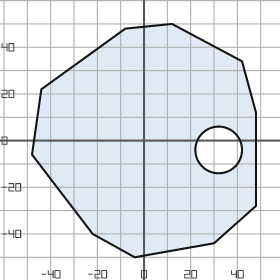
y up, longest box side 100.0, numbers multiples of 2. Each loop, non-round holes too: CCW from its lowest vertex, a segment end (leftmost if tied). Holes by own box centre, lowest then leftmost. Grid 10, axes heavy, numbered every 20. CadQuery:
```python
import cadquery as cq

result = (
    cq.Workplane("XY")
    .moveTo(-4.0, -50.0)
    .lineTo(30.0, -44.0)
    .lineTo(48.0, -28.0)
    .lineTo(48.0, 12.0)
    .lineTo(42.0, 34.0)
    .lineTo(12.0, 50.0)
    .lineTo(-8.0, 48.0)
    .lineTo(-44.0, 22.0)
    .lineTo(-48.0, -6.0)
    .lineTo(-22.0, -40.0)
    .close()
    .moveTo(32.0, -4.0)
    .circle(10.0)
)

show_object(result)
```